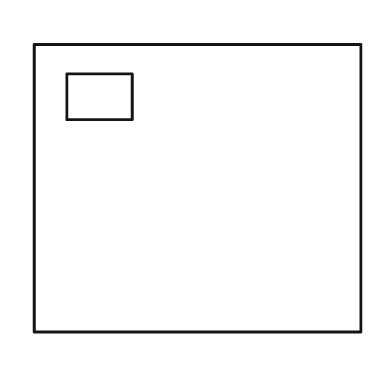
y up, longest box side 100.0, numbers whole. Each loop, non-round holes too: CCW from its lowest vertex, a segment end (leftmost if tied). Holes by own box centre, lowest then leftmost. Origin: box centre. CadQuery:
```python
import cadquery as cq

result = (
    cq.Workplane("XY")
    .moveTo(-50.0, -44.0)
    .lineTo(50.0, -44.0)
    .lineTo(50.0, 44.0)
    .lineTo(-50.0, 44.0)
    .close()
    .moveTo(-40.0, 21.0)
    .lineTo(-20.0, 21.0)
    .lineTo(-20.0, 35.0)
    .lineTo(-40.0, 35.0)
    .close()
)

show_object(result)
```